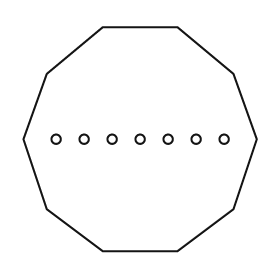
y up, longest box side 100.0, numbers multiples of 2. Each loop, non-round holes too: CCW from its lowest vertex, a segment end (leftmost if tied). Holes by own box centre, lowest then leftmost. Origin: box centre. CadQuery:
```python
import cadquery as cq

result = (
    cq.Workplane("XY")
    .moveTo(-16.0, -48.0)
    .lineTo(16.0, -48.0)
    .lineTo(40.0, -30.0)
    .lineTo(50.0, 0.0)
    .lineTo(40.0, 28.0)
    .lineTo(16.0, 48.0)
    .lineTo(-16.0, 48.0)
    .lineTo(-40.0, 28.0)
    .lineTo(-50.0, 0.0)
    .lineTo(-40.0, -30.0)
    .close()
    .moveTo(-36.0, 0.0)
    .circle(2.0)
    .moveTo(-24.0, 0.0)
    .circle(2.0)
    .moveTo(-12.0, 0.0)
    .circle(2.0)
    .moveTo(0.0, 0.0)
    .circle(2.0)
    .moveTo(12.0, 0.0)
    .circle(2.0)
    .moveTo(24.0, 0.0)
    .circle(2.0)
    .moveTo(36.0, 0.0)
    .circle(2.0)
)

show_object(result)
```